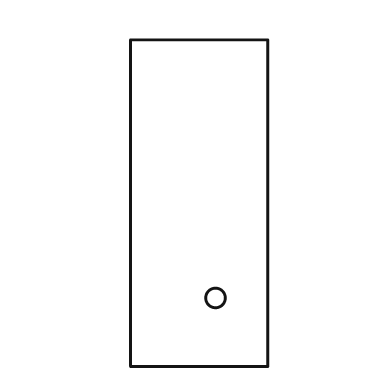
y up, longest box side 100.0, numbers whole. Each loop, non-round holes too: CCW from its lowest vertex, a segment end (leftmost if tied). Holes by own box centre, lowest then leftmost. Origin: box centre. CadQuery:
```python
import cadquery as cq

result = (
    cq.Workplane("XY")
    .moveTo(-21.0, -50.0)
    .lineTo(21.0, -50.0)
    .lineTo(21.0, 50.0)
    .lineTo(-21.0, 50.0)
    .close()
    .moveTo(5.0, -29.0)
    .circle(3.0)
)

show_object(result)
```